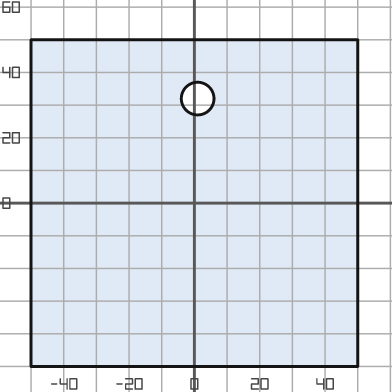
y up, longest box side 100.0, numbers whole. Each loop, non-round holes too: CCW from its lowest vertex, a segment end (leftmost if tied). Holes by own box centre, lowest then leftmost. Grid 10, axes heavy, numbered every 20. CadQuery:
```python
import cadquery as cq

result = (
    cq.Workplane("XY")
    .moveTo(-50.0, -50.0)
    .lineTo(50.0, -50.0)
    .lineTo(50.0, 50.0)
    .lineTo(-50.0, 50.0)
    .close()
    .moveTo(1.0, 32.0)
    .circle(5.0)
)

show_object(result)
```